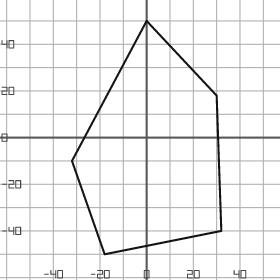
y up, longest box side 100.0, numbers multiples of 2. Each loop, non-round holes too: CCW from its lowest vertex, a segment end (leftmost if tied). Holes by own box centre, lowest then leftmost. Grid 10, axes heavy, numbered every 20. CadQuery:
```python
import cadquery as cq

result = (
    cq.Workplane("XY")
    .moveTo(-18.0, -50.0)
    .lineTo(32.0, -40.0)
    .lineTo(30.0, 18.0)
    .lineTo(0.0, 50.0)
    .lineTo(-32.0, -10.0)
    .close()
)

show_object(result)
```